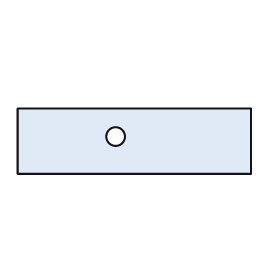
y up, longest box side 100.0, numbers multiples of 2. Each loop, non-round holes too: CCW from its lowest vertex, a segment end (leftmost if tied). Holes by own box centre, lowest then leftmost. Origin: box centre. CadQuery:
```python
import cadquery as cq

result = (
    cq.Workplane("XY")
    .moveTo(-50.0, -14.0)
    .lineTo(50.0, -14.0)
    .lineTo(50.0, 14.0)
    .lineTo(-50.0, 14.0)
    .close()
    .moveTo(-8.0, 2.0)
    .circle(4.0)
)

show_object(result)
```